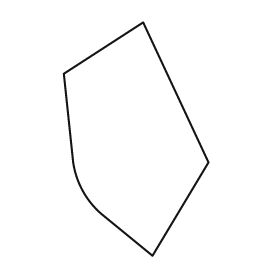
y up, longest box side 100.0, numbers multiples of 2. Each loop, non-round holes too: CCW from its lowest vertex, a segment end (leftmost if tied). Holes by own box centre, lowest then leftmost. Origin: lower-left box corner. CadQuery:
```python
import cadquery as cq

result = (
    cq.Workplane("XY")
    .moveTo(38.0, 0.0)
    .lineTo(62.0, 40.0)
    .lineTo(34.0, 100.0)
    .lineTo(0.0, 78.0)
    .lineTo(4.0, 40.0)
    .threePointArc((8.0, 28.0), (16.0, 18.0))
    .close()
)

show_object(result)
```